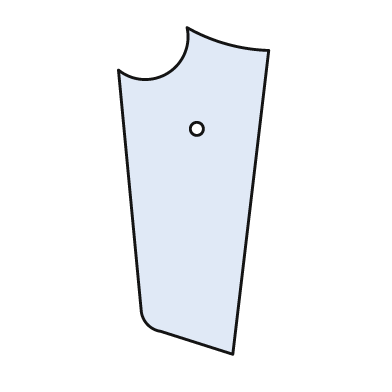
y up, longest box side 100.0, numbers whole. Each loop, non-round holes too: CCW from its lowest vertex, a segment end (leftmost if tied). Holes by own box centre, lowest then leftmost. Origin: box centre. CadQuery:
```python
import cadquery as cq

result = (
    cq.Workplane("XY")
    .moveTo(12.0, -50.0)
    .lineTo(23.0, 43.0)
    .threePointArc((10.0, 45.0), (-2.0, 50.0))
    .threePointArc((-8.0, 36.0), (-23.0, 37.0))
    .lineTo(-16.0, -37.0)
    .threePointArc((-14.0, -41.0), (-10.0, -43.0))
    .close()
    .moveTo(1.0, 19.0)
    .circle(2.0)
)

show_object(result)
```